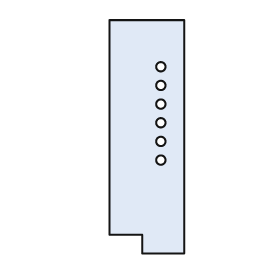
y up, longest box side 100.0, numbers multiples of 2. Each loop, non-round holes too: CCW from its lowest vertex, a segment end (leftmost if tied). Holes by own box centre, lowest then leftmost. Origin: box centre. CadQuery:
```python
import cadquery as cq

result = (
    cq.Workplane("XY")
    .moveTo(-2.0, -50.0)
    .lineTo(16.0, -50.0)
    .lineTo(16.0, 50.0)
    .lineTo(-16.0, 50.0)
    .lineTo(-16.0, -42.0)
    .lineTo(-2.0, -42.0)
    .close()
    .moveTo(6.0, -10.0)
    .circle(2.0)
    .moveTo(6.0, -2.0)
    .circle(2.0)
    .moveTo(6.0, 6.0)
    .circle(2.0)
    .moveTo(6.0, 14.0)
    .circle(2.0)
    .moveTo(6.0, 22.0)
    .circle(2.0)
    .moveTo(6.0, 30.0)
    .circle(2.0)
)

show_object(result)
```